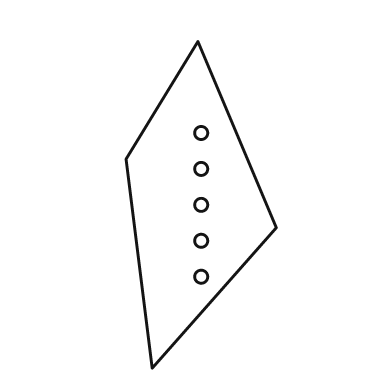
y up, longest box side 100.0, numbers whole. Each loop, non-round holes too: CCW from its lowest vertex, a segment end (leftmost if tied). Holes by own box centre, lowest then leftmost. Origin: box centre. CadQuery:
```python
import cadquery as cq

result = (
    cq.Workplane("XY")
    .moveTo(-15.0, -50.0)
    .lineTo(23.0, -7.0)
    .lineTo(-1.0, 50.0)
    .lineTo(-23.0, 14.0)
    .close()
    .moveTo(0.0, -22.0)
    .circle(2.0)
    .moveTo(0.0, -11.0)
    .circle(2.0)
    .moveTo(0.0, 0.0)
    .circle(2.0)
    .moveTo(0.0, 11.0)
    .circle(2.0)
    .moveTo(0.0, 22.0)
    .circle(2.0)
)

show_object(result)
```